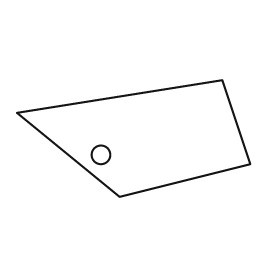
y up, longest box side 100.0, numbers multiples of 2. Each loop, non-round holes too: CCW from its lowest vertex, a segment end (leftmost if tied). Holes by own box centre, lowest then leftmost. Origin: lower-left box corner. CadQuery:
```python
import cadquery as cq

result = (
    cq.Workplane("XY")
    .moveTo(44.0, 0.0)
    .lineTo(100.0, 14.0)
    .lineTo(88.0, 50.0)
    .lineTo(0.0, 36.0)
    .close()
    .moveTo(36.0, 18.0)
    .circle(4.0)
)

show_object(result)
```